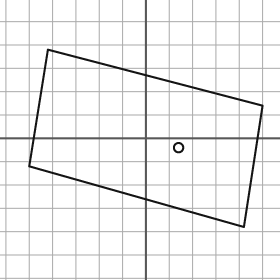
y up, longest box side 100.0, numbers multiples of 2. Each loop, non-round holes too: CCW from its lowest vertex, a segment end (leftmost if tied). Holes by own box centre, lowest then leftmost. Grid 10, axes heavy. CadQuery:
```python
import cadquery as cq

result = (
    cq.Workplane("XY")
    .moveTo(42.0, -38.0)
    .lineTo(50.0, 14.0)
    .lineTo(-42.0, 38.0)
    .lineTo(-50.0, -12.0)
    .close()
    .moveTo(14.0, -4.0)
    .circle(2.0)
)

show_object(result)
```